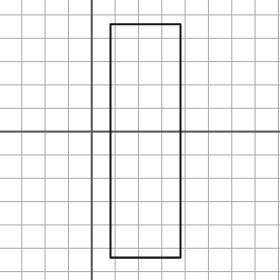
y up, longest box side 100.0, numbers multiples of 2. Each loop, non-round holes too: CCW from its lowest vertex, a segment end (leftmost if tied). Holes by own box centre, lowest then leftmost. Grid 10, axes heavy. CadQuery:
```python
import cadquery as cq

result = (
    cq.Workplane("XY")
    .moveTo(8.0, -54.0)
    .lineTo(38.0, -54.0)
    .lineTo(38.0, 46.0)
    .lineTo(8.0, 46.0)
    .close()
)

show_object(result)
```